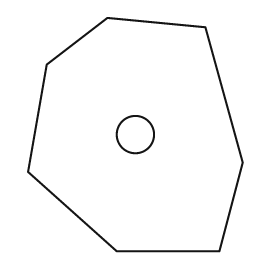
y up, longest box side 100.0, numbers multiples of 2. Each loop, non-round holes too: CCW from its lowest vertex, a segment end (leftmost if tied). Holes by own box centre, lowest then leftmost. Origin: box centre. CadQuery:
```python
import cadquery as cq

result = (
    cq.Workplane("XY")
    .moveTo(-8.0, -50.0)
    .lineTo(36.0, -50.0)
    .lineTo(46.0, -12.0)
    .lineTo(30.0, 46.0)
    .lineTo(-12.0, 50.0)
    .lineTo(-38.0, 30.0)
    .lineTo(-46.0, -16.0)
    .close()
    .moveTo(0.0, 0.0)
    .circle(8.0)
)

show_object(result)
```